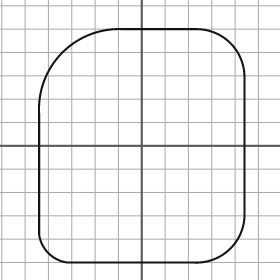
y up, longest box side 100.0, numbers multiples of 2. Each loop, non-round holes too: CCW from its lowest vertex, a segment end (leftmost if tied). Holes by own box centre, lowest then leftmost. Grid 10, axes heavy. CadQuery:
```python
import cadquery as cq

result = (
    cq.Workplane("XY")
    .moveTo(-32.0, -50.0)
    .lineTo(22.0, -50.0)
    .threePointArc((38.0, -44.0), (44.0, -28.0))
    .lineTo(44.0, 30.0)
    .threePointArc((38.0, 44.0), (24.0, 50.0))
    .lineTo(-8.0, 50.0)
    .threePointArc((-34.0, 40.0), (-44.0, 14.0))
    .lineTo(-44.0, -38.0)
    .threePointArc((-40.0, -46.0), (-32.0, -50.0))
    .close()
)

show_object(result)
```